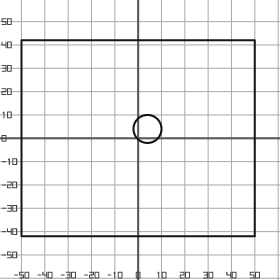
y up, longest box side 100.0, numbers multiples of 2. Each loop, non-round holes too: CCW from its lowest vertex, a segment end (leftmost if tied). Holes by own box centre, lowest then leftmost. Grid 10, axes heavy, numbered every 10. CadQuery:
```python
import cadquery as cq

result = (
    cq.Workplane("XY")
    .moveTo(-50.0, -42.0)
    .lineTo(50.0, -42.0)
    .lineTo(50.0, 42.0)
    .lineTo(-50.0, 42.0)
    .close()
    .moveTo(4.0, 4.0)
    .circle(6.0)
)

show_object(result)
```